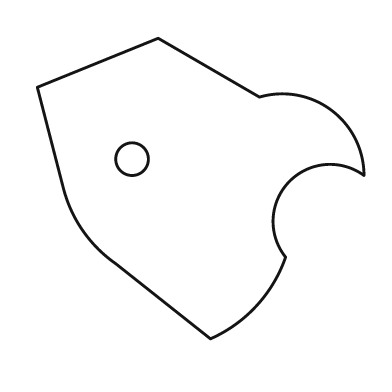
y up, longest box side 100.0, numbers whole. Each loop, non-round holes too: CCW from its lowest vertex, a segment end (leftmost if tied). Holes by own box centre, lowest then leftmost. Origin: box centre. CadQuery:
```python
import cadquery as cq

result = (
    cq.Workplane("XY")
    .moveTo(3.0, -46.0)
    .threePointArc((17.0, -36.0), (26.0, -21.0))
    .threePointArc((27.0, 2.0), (50.0, 4.0))
    .threePointArc((40.0, 24.0), (18.0, 28.0))
    .lineTo(-13.0, 46.0)
    .lineTo(-50.0, 31.0)
    .lineTo(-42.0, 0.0)
    .threePointArc((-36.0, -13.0), (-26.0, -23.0))
    .close()
    .moveTo(-21.0, 9.0)
    .circle(5.0)
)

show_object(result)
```